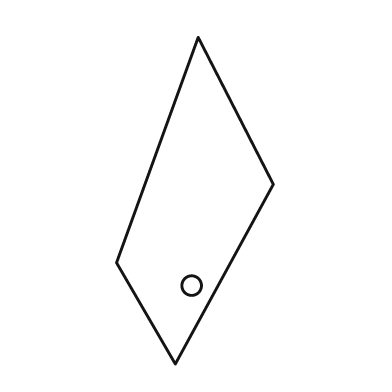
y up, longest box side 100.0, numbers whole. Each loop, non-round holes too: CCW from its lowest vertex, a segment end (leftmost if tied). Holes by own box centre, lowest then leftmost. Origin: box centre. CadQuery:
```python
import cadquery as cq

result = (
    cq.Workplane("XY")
    .moveTo(-6.0, -50.0)
    .lineTo(24.0, 5.0)
    .lineTo(1.0, 50.0)
    .lineTo(-24.0, -19.0)
    .close()
    .moveTo(-1.0, -26.0)
    .circle(3.0)
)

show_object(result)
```